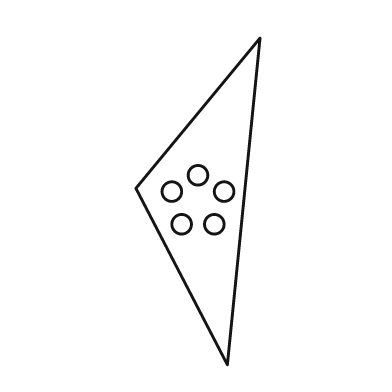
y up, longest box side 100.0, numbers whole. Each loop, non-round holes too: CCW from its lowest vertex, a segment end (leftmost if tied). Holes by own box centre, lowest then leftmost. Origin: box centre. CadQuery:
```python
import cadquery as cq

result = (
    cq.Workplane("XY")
    .moveTo(9.0, -50.0)
    .lineTo(19.0, 50.0)
    .lineTo(-19.0, 4.0)
    .close()
    .moveTo(-5.0, -7.0)
    .circle(3.0)
    .moveTo(5.0, -7.0)
    .circle(3.0)
    .moveTo(-8.0, 3.0)
    .circle(3.0)
    .moveTo(8.0, 3.0)
    .circle(3.0)
    .moveTo(0.0, 8.0)
    .circle(3.0)
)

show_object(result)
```